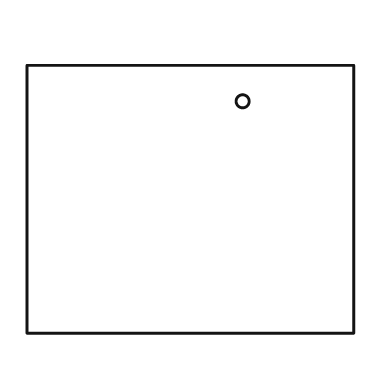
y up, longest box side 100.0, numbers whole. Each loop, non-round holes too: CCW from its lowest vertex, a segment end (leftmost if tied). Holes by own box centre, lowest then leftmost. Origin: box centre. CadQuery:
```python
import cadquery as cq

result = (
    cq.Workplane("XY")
    .moveTo(-50.0, -41.0)
    .lineTo(50.0, -41.0)
    .lineTo(50.0, 41.0)
    .lineTo(-50.0, 41.0)
    .close()
    .moveTo(16.0, 30.0)
    .circle(2.0)
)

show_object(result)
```